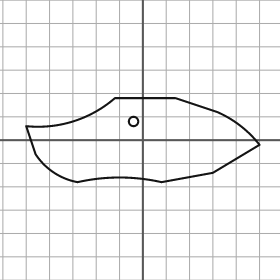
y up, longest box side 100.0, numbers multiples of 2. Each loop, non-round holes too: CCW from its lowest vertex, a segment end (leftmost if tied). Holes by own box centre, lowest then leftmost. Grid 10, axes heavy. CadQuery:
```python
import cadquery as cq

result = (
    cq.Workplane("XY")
    .moveTo(-28.0, -18.0)
    .threePointArc((-10.0, -16.0), (8.0, -18.0))
    .lineTo(30.0, -14.0)
    .lineTo(50.0, -2.0)
    .threePointArc((42.0, 6.0), (32.0, 12.0))
    .lineTo(14.0, 18.0)
    .lineTo(-12.0, 18.0)
    .threePointArc((-30.0, 8.0), (-50.0, 6.0))
    .lineTo(-46.0, -6.0)
    .threePointArc((-38.0, -14.0), (-28.0, -18.0))
    .close()
    .moveTo(-4.0, 8.0)
    .circle(2.0)
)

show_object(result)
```